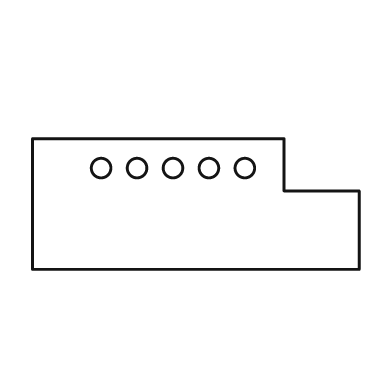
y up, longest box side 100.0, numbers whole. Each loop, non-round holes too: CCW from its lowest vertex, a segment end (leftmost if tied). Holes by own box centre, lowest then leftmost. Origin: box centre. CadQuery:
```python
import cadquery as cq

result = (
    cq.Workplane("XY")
    .moveTo(-50.0, -20.0)
    .lineTo(50.0, -20.0)
    .lineTo(50.0, 4.0)
    .lineTo(27.0, 4.0)
    .lineTo(27.0, 20.0)
    .lineTo(-50.0, 20.0)
    .close()
    .moveTo(-29.0, 11.0)
    .circle(3.0)
    .moveTo(-18.0, 11.0)
    .circle(3.0)
    .moveTo(-7.0, 11.0)
    .circle(3.0)
    .moveTo(4.0, 11.0)
    .circle(3.0)
    .moveTo(15.0, 11.0)
    .circle(3.0)
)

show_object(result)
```